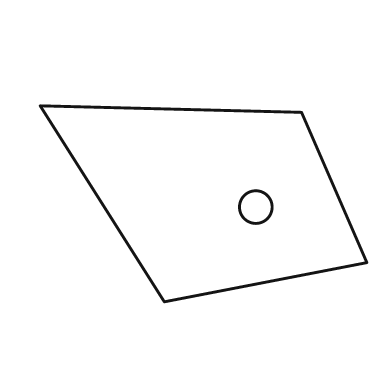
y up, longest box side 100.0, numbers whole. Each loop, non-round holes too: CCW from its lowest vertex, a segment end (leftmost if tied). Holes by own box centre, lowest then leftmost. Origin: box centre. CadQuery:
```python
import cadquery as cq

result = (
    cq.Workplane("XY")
    .moveTo(-12.0, -30.0)
    .lineTo(50.0, -18.0)
    .lineTo(30.0, 28.0)
    .lineTo(-50.0, 30.0)
    .close()
    .moveTo(16.0, -1.0)
    .circle(5.0)
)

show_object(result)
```